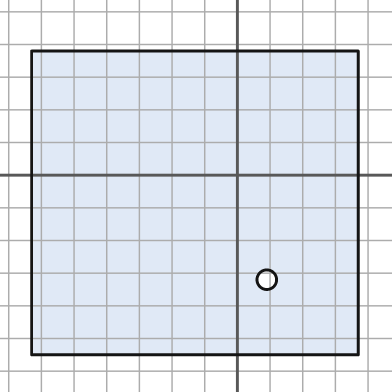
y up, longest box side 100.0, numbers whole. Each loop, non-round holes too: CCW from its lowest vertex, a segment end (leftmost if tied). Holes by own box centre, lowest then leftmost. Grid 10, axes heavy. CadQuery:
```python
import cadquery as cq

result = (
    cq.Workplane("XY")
    .moveTo(-63.0, -55.0)
    .lineTo(37.0, -55.0)
    .lineTo(37.0, 38.0)
    .lineTo(-63.0, 38.0)
    .close()
    .moveTo(9.0, -32.0)
    .circle(3.0)
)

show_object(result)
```